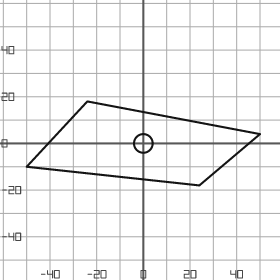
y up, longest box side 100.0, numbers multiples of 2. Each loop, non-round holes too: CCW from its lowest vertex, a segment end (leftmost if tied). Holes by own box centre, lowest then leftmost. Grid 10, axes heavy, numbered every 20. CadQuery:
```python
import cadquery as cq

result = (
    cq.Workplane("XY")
    .moveTo(24.0, -18.0)
    .lineTo(50.0, 4.0)
    .lineTo(-24.0, 18.0)
    .lineTo(-50.0, -10.0)
    .close()
    .moveTo(0.0, 0.0)
    .circle(4.0)
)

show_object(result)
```